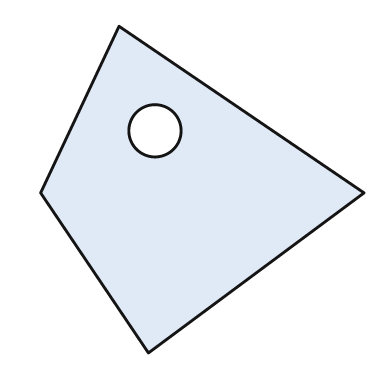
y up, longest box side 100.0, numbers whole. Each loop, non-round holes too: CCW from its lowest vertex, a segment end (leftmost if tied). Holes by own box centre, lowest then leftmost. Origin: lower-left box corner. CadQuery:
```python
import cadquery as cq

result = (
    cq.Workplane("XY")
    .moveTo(33.0, 0.0)
    .lineTo(99.0, 49.0)
    .lineTo(24.0, 100.0)
    .lineTo(0.0, 49.0)
    .close()
    .moveTo(35.0, 68.0)
    .circle(8.0)
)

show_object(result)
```